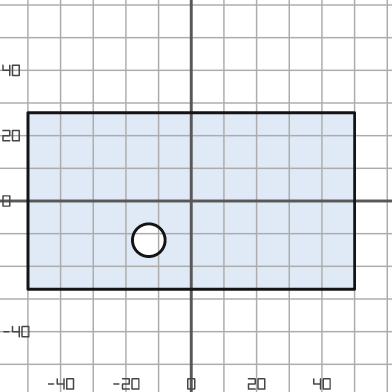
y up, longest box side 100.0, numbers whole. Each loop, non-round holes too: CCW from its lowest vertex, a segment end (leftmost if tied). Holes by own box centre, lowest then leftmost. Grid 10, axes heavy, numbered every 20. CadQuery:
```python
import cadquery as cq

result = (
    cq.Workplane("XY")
    .moveTo(-50.0, -27.0)
    .lineTo(50.0, -27.0)
    .lineTo(50.0, 27.0)
    .lineTo(-50.0, 27.0)
    .close()
    .moveTo(-13.0, -12.0)
    .circle(5.0)
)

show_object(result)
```